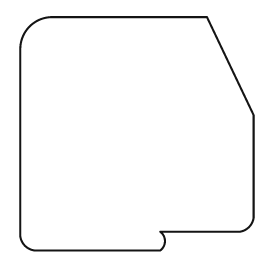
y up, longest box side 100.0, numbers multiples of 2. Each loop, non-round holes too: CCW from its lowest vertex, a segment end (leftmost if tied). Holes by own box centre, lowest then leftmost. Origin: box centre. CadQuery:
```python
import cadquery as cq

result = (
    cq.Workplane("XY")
    .moveTo(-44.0, -50.0)
    .lineTo(10.0, -50.0)
    .threePointArc((12.0, -46.0), (10.0, -42.0))
    .lineTo(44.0, -42.0)
    .threePointArc((48.0, -40.0), (50.0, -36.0))
    .lineTo(50.0, 8.0)
    .lineTo(30.0, 50.0)
    .lineTo(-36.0, 50.0)
    .threePointArc((-46.0, 46.0), (-50.0, 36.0))
    .lineTo(-50.0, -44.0)
    .threePointArc((-48.0, -48.0), (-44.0, -50.0))
    .close()
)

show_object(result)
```